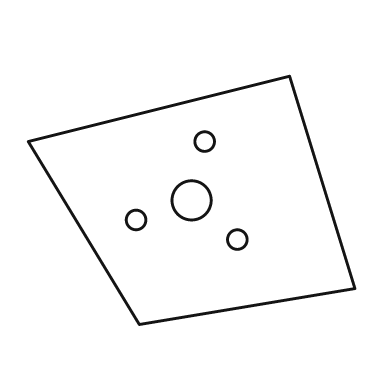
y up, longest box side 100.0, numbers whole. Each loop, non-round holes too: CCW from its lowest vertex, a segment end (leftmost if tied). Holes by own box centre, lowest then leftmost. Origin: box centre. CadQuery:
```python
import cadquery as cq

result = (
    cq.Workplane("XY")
    .moveTo(-16.0, -38.0)
    .lineTo(50.0, -27.0)
    .lineTo(30.0, 38.0)
    .lineTo(-50.0, 18.0)
    .close()
    .moveTo(14.0, -12.0)
    .circle(3.0)
    .moveTo(-17.0, -6.0)
    .circle(3.0)
    .moveTo(0.0, 0.0)
    .circle(6.0)
    .moveTo(4.0, 18.0)
    .circle(3.0)
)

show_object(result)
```